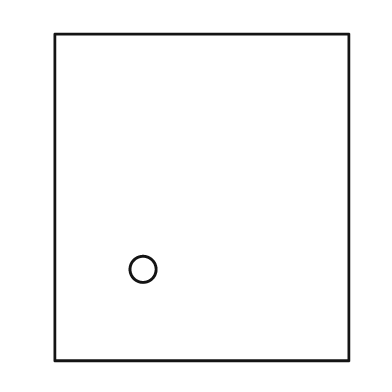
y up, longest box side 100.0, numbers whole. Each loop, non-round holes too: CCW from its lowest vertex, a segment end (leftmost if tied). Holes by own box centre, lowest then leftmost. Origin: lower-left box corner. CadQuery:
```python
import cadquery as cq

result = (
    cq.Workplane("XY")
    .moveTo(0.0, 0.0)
    .lineTo(90.0, 0.0)
    .lineTo(90.0, 100.0)
    .lineTo(0.0, 100.0)
    .close()
    .moveTo(27.0, 28.0)
    .circle(4.0)
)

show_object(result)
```